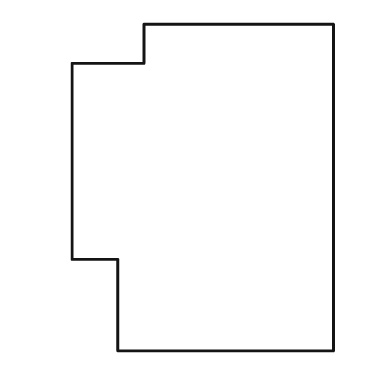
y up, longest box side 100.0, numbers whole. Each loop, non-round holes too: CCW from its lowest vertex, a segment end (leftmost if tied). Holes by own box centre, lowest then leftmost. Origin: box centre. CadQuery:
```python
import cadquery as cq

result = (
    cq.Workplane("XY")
    .moveTo(-26.0, -50.0)
    .lineTo(40.0, -50.0)
    .lineTo(40.0, 50.0)
    .lineTo(-18.0, 50.0)
    .lineTo(-18.0, 38.0)
    .lineTo(-40.0, 38.0)
    .lineTo(-40.0, -22.0)
    .lineTo(-26.0, -22.0)
    .close()
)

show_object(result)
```